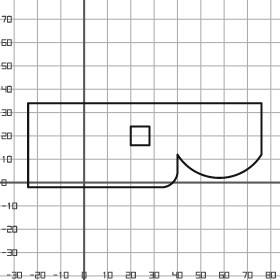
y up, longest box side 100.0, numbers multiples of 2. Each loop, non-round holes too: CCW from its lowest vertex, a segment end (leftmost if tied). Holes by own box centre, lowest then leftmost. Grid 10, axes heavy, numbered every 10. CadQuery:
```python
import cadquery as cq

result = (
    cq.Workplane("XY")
    .moveTo(-24.0, -2.0)
    .lineTo(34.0, -2.0)
    .threePointArc((38.0, 0.0), (40.0, 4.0))
    .lineTo(40.0, 12.0)
    .threePointArc((58.0, 2.0), (76.0, 12.0))
    .lineTo(76.0, 34.0)
    .lineTo(-24.0, 34.0)
    .close()
    .moveTo(20.0, 16.0)
    .lineTo(28.0, 16.0)
    .lineTo(28.0, 24.0)
    .lineTo(20.0, 24.0)
    .close()
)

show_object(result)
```